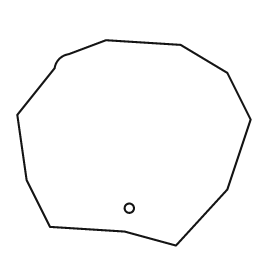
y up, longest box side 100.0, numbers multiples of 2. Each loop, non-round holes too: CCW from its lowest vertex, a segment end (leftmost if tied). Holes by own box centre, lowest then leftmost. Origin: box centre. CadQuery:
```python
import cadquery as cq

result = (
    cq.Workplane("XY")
    .moveTo(18.0, -44.0)
    .lineTo(40.0, -20.0)
    .lineTo(50.0, 10.0)
    .lineTo(40.0, 30.0)
    .lineTo(20.0, 42.0)
    .lineTo(-12.0, 44.0)
    .lineTo(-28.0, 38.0)
    .threePointArc((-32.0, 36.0), (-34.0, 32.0))
    .lineTo(-50.0, 12.0)
    .lineTo(-46.0, -16.0)
    .lineTo(-36.0, -36.0)
    .lineTo(-4.0, -38.0)
    .close()
    .moveTo(-2.0, -28.0)
    .circle(2.0)
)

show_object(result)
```